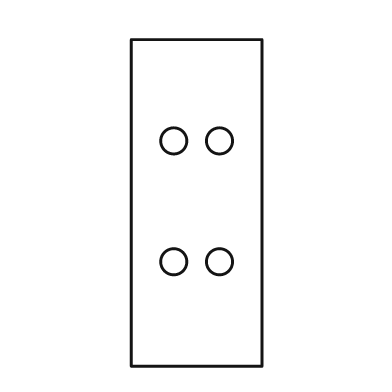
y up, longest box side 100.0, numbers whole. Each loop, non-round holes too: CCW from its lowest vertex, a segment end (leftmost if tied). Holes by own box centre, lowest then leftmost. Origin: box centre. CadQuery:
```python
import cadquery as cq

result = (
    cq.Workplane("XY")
    .moveTo(-20.0, -50.0)
    .lineTo(20.0, -50.0)
    .lineTo(20.0, 50.0)
    .lineTo(-20.0, 50.0)
    .close()
    .moveTo(-7.0, -18.0)
    .circle(4.0)
    .moveTo(7.0, -18.0)
    .circle(4.0)
    .moveTo(-7.0, 19.0)
    .circle(4.0)
    .moveTo(7.0, 19.0)
    .circle(4.0)
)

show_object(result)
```